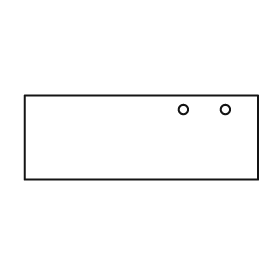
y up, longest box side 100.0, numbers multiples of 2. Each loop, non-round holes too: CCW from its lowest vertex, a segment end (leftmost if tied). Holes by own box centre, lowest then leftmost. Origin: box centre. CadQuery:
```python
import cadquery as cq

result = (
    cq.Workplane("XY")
    .moveTo(-50.0, -18.0)
    .lineTo(50.0, -18.0)
    .lineTo(50.0, 18.0)
    .lineTo(-50.0, 18.0)
    .close()
    .moveTo(18.0, 12.0)
    .circle(2.0)
    .moveTo(36.0, 12.0)
    .circle(2.0)
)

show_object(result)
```